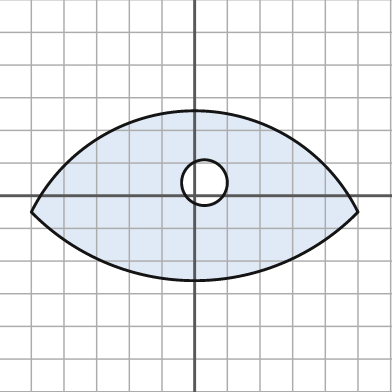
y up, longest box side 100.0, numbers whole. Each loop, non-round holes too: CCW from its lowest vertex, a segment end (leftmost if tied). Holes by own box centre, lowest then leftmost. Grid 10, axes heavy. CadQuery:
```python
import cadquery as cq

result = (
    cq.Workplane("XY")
    .moveTo(-50.0, -5.0)
    .threePointArc((0.0, -26.0), (50.0, -5.0))
    .threePointArc((0.0, 26.0), (-50.0, -5.0))
    .close()
    .moveTo(3.0, 4.0)
    .circle(7.0)
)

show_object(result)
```